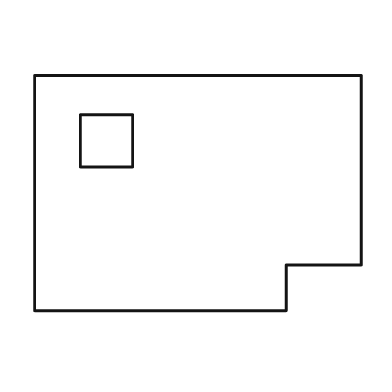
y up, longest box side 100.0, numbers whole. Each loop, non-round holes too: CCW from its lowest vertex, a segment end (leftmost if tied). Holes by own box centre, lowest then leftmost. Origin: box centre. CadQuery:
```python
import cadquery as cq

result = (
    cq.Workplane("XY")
    .moveTo(-50.0, -36.0)
    .lineTo(27.0, -36.0)
    .lineTo(27.0, -22.0)
    .lineTo(50.0, -22.0)
    .lineTo(50.0, 36.0)
    .lineTo(-50.0, 36.0)
    .close()
    .moveTo(-36.0, 8.0)
    .lineTo(-20.0, 8.0)
    .lineTo(-20.0, 24.0)
    .lineTo(-36.0, 24.0)
    .close()
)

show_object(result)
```